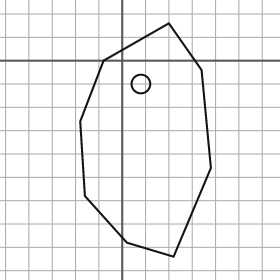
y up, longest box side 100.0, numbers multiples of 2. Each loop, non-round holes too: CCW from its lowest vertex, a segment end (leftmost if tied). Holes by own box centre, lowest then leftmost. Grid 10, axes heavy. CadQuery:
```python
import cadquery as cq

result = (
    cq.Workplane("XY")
    .moveTo(22.0, -84.0)
    .lineTo(38.0, -46.0)
    .lineTo(34.0, -4.0)
    .lineTo(20.0, 16.0)
    .lineTo(-8.0, 0.0)
    .lineTo(-18.0, -26.0)
    .lineTo(-16.0, -58.0)
    .lineTo(2.0, -78.0)
    .close()
    .moveTo(8.0, -10.0)
    .circle(4.0)
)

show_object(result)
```